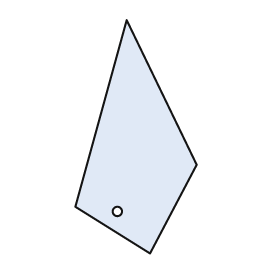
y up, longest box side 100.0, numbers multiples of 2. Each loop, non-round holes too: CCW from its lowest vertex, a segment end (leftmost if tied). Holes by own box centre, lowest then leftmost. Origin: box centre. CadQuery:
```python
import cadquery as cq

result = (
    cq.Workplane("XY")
    .moveTo(6.0, -50.0)
    .lineTo(26.0, -12.0)
    .lineTo(-4.0, 50.0)
    .lineTo(-26.0, -30.0)
    .close()
    .moveTo(-8.0, -32.0)
    .circle(2.0)
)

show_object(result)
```